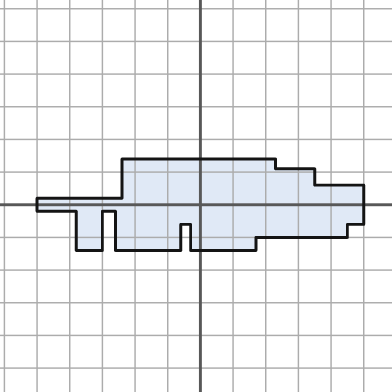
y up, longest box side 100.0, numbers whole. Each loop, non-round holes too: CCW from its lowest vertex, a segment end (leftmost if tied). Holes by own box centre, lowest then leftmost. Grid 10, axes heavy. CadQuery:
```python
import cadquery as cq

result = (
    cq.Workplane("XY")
    .moveTo(-38.0, -14.0)
    .lineTo(-30.0, -14.0)
    .lineTo(-30.0, -2.0)
    .lineTo(-26.0, -2.0)
    .lineTo(-26.0, -14.0)
    .lineTo(-6.0, -14.0)
    .lineTo(-6.0, -6.0)
    .lineTo(-3.0, -6.0)
    .lineTo(-3.0, -14.0)
    .lineTo(17.0, -14.0)
    .lineTo(17.0, -10.0)
    .lineTo(45.0, -10.0)
    .lineTo(45.0, -6.0)
    .lineTo(50.0, -6.0)
    .lineTo(50.0, 6.0)
    .lineTo(35.0, 6.0)
    .lineTo(35.0, 11.0)
    .lineTo(23.0, 11.0)
    .lineTo(23.0, 14.0)
    .lineTo(-24.0, 14.0)
    .lineTo(-24.0, 2.0)
    .lineTo(-50.0, 2.0)
    .lineTo(-50.0, -2.0)
    .lineTo(-38.0, -2.0)
    .close()
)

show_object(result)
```